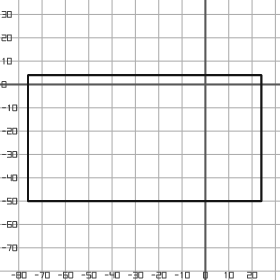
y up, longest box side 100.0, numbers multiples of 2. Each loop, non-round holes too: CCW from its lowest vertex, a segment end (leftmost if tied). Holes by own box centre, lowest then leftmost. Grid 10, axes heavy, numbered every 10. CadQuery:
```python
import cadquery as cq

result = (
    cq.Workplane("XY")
    .moveTo(-76.0, -50.0)
    .lineTo(24.0, -50.0)
    .lineTo(24.0, 4.0)
    .lineTo(-76.0, 4.0)
    .close()
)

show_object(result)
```